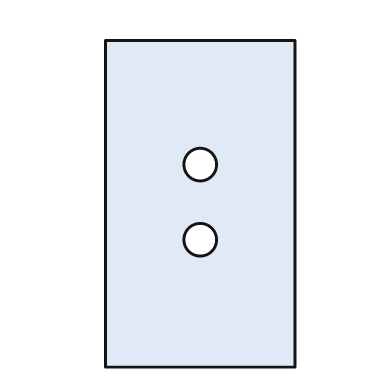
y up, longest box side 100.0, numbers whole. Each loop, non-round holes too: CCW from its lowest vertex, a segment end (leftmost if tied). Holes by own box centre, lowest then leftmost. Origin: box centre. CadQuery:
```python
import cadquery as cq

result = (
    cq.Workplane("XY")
    .moveTo(-29.0, -50.0)
    .lineTo(29.0, -50.0)
    .lineTo(29.0, 50.0)
    .lineTo(-29.0, 50.0)
    .close()
    .moveTo(0.0, -11.0)
    .circle(5.0)
    .moveTo(0.0, 12.0)
    .circle(5.0)
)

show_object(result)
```